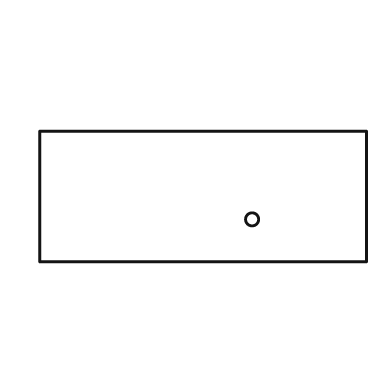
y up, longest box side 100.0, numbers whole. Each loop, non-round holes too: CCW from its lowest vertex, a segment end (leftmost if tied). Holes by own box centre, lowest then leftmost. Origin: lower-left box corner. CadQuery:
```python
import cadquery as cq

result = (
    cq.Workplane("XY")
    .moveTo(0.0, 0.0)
    .lineTo(100.0, 0.0)
    .lineTo(100.0, 40.0)
    .lineTo(0.0, 40.0)
    .close()
    .moveTo(65.0, 13.0)
    .circle(2.0)
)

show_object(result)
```